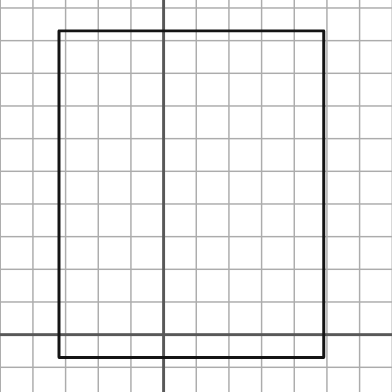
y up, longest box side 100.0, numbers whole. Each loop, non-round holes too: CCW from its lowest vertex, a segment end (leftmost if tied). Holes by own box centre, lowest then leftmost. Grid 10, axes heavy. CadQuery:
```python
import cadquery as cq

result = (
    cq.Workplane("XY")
    .moveTo(-32.0, -7.0)
    .lineTo(49.0, -7.0)
    .lineTo(49.0, 93.0)
    .lineTo(-32.0, 93.0)
    .close()
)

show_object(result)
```